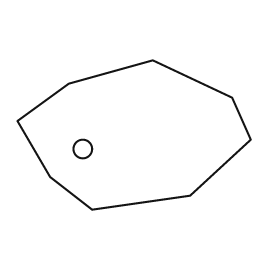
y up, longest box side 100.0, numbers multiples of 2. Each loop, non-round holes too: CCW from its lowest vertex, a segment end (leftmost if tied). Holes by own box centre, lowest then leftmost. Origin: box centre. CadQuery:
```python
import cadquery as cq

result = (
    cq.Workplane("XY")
    .moveTo(-18.0, -32.0)
    .lineTo(24.0, -26.0)
    .lineTo(50.0, -2.0)
    .lineTo(42.0, 16.0)
    .lineTo(8.0, 32.0)
    .lineTo(-28.0, 22.0)
    .lineTo(-50.0, 6.0)
    .lineTo(-36.0, -18.0)
    .close()
    .moveTo(-22.0, -6.0)
    .circle(4.0)
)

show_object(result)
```